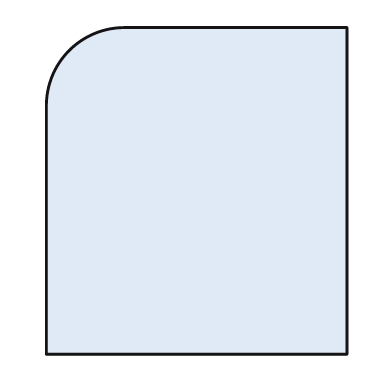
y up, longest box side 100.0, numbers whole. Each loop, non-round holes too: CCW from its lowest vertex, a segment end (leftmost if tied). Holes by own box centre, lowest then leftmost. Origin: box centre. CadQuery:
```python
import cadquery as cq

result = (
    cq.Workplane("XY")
    .moveTo(-46.0, -50.0)
    .lineTo(46.0, -50.0)
    .lineTo(46.0, 50.0)
    .lineTo(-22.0, 50.0)
    .threePointArc((-39.0, 43.0), (-46.0, 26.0))
    .close()
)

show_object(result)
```